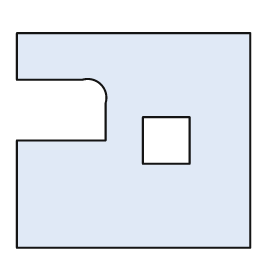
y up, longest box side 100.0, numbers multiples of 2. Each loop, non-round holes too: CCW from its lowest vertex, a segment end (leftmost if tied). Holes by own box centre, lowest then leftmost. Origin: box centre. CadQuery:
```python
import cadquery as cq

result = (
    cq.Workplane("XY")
    .moveTo(-50.0, -46.0)
    .lineTo(50.0, -46.0)
    .lineTo(50.0, 46.0)
    .lineTo(-50.0, 46.0)
    .lineTo(-50.0, 26.0)
    .lineTo(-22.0, 26.0)
    .threePointArc((-14.0, 24.0), (-12.0, 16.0))
    .lineTo(-12.0, 0.0)
    .lineTo(-50.0, 0.0)
    .close()
    .moveTo(4.0, -10.0)
    .lineTo(24.0, -10.0)
    .lineTo(24.0, 10.0)
    .lineTo(4.0, 10.0)
    .close()
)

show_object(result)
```